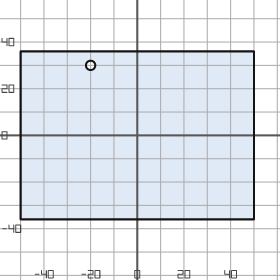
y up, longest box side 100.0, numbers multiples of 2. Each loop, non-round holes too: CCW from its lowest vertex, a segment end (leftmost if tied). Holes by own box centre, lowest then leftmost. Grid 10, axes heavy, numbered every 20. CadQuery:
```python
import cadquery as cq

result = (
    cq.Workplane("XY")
    .moveTo(-50.0, -36.0)
    .lineTo(50.0, -36.0)
    .lineTo(50.0, 36.0)
    .lineTo(-50.0, 36.0)
    .close()
    .moveTo(-20.0, 30.0)
    .circle(2.0)
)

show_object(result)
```